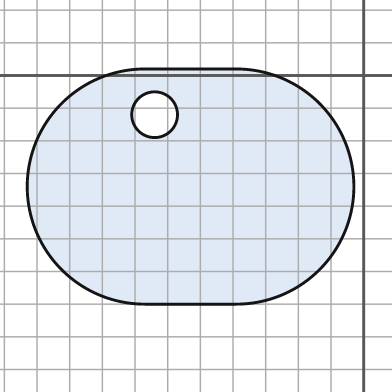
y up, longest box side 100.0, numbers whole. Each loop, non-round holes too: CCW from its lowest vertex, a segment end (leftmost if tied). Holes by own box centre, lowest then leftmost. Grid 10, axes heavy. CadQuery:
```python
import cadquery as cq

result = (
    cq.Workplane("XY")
    .moveTo(-67.0, -70.0)
    .lineTo(-39.0, -70.0)
    .threePointArc((-3.0, -34.0), (-39.0, 2.0))
    .lineTo(-67.0, 2.0)
    .threePointArc((-103.0, -34.0), (-67.0, -70.0))
    .close()
    .moveTo(-64.0, -12.0)
    .circle(7.0)
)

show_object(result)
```